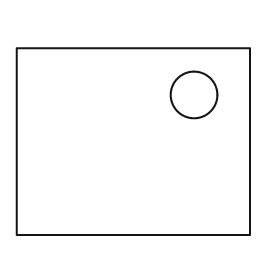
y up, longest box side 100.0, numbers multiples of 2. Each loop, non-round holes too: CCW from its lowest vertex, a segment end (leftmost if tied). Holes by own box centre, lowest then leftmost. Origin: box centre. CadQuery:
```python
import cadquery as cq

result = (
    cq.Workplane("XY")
    .moveTo(-50.0, -40.0)
    .lineTo(50.0, -40.0)
    .lineTo(50.0, 40.0)
    .lineTo(-50.0, 40.0)
    .close()
    .moveTo(26.0, 20.0)
    .circle(10.0)
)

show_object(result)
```